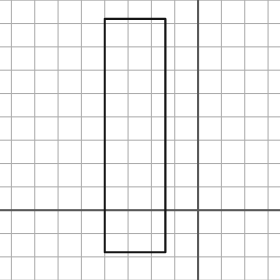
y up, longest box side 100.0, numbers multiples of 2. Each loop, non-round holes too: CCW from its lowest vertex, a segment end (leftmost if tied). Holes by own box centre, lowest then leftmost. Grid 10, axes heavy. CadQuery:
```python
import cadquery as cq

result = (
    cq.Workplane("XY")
    .moveTo(-40.0, -18.0)
    .lineTo(-14.0, -18.0)
    .lineTo(-14.0, 82.0)
    .lineTo(-40.0, 82.0)
    .close()
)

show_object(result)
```